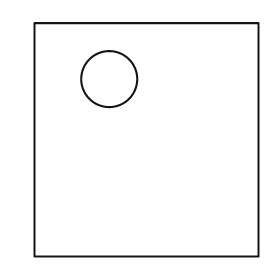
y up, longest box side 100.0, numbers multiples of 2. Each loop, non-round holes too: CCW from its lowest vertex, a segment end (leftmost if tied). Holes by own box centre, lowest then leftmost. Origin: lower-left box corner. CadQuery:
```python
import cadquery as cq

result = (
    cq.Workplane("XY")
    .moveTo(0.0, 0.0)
    .lineTo(96.0, 0.0)
    .lineTo(96.0, 100.0)
    .lineTo(0.0, 100.0)
    .close()
    .moveTo(32.0, 76.0)
    .circle(12.0)
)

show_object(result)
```